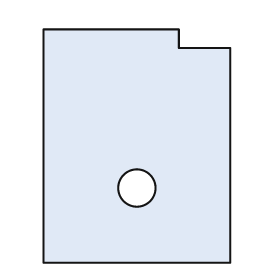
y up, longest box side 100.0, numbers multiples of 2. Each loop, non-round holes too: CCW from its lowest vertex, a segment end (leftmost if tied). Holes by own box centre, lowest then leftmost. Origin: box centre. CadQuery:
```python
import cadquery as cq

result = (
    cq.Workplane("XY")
    .moveTo(-40.0, -50.0)
    .lineTo(40.0, -50.0)
    .lineTo(40.0, 42.0)
    .lineTo(18.0, 42.0)
    .lineTo(18.0, 50.0)
    .lineTo(-40.0, 50.0)
    .close()
    .moveTo(0.0, -18.0)
    .circle(8.0)
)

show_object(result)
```